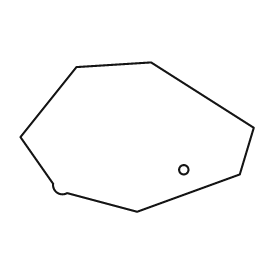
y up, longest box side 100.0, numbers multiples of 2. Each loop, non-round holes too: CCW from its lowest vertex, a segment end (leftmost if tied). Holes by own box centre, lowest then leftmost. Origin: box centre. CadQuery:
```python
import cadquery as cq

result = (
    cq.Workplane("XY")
    .moveTo(0.0, -32.0)
    .lineTo(44.0, -16.0)
    .lineTo(50.0, 4.0)
    .lineTo(6.0, 32.0)
    .lineTo(-26.0, 30.0)
    .lineTo(-50.0, 0.0)
    .lineTo(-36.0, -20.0)
    .threePointArc((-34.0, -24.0), (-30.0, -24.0))
    .close()
    .moveTo(20.0, -14.0)
    .circle(2.0)
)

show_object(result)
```